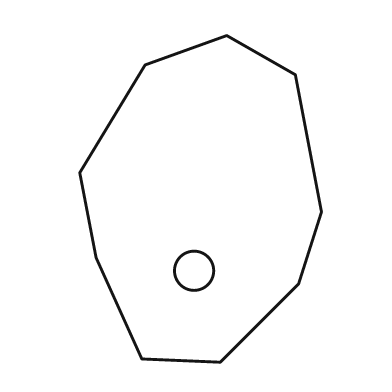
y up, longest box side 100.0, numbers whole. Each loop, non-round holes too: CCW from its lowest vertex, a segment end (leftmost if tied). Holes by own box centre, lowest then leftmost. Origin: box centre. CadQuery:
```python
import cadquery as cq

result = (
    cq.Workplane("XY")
    .moveTo(6.0, -50.0)
    .lineTo(30.0, -26.0)
    .lineTo(37.0, -4.0)
    .lineTo(29.0, 38.0)
    .lineTo(8.0, 50.0)
    .lineTo(-17.0, 41.0)
    .lineTo(-37.0, 8.0)
    .lineTo(-32.0, -18.0)
    .lineTo(-18.0, -49.0)
    .close()
    .moveTo(-2.0, -22.0)
    .circle(6.0)
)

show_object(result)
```